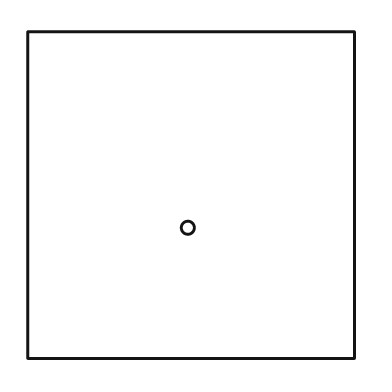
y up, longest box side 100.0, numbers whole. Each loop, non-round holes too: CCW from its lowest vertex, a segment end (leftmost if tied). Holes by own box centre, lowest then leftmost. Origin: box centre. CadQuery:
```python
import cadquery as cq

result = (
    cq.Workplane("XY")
    .moveTo(-50.0, -50.0)
    .lineTo(50.0, -50.0)
    .lineTo(50.0, 50.0)
    .lineTo(-50.0, 50.0)
    .close()
    .moveTo(-1.0, -10.0)
    .circle(2.0)
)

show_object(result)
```